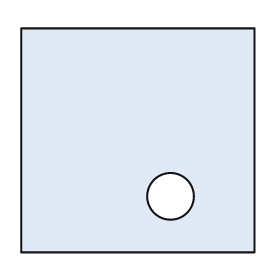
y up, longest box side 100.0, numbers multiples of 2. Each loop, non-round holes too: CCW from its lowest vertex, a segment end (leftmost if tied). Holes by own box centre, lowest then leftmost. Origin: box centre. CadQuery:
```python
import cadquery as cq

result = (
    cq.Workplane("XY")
    .moveTo(-50.0, -48.0)
    .lineTo(50.0, -48.0)
    .lineTo(50.0, 48.0)
    .lineTo(-50.0, 48.0)
    .close()
    .moveTo(14.0, -24.0)
    .circle(10.0)
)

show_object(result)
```